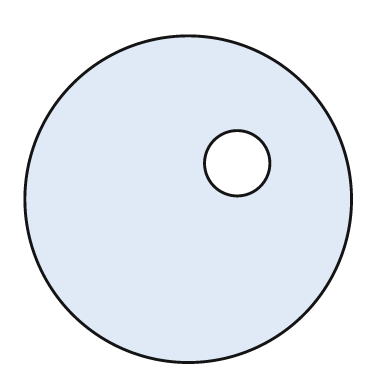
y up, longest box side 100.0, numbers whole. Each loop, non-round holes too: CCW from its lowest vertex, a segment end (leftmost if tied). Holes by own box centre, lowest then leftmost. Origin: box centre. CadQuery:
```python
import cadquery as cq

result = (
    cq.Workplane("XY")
    .moveTo(0.0, 0.0)
    .circle(50.0)
    .moveTo(15.0, 11.0)
    .circle(10.0)
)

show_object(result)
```